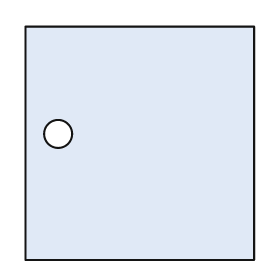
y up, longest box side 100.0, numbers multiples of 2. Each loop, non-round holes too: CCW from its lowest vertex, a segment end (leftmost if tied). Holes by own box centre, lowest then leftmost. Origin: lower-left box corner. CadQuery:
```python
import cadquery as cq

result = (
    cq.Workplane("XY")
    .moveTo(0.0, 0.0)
    .lineTo(98.0, 0.0)
    .lineTo(98.0, 100.0)
    .lineTo(0.0, 100.0)
    .close()
    .moveTo(14.0, 54.0)
    .circle(6.0)
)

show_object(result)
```